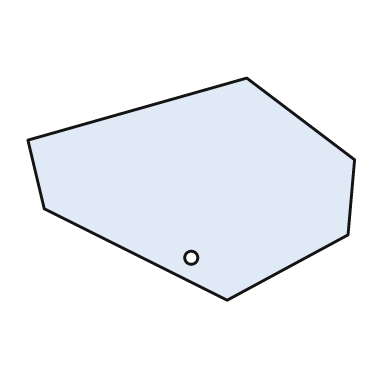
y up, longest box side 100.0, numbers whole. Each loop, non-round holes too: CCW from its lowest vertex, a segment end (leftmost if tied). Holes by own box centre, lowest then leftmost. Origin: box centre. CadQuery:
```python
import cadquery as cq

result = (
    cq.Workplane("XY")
    .moveTo(11.0, -34.0)
    .lineTo(48.0, -14.0)
    .lineTo(50.0, 9.0)
    .lineTo(17.0, 34.0)
    .lineTo(-50.0, 15.0)
    .lineTo(-45.0, -6.0)
    .close()
    .moveTo(0.0, -21.0)
    .circle(2.0)
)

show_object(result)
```